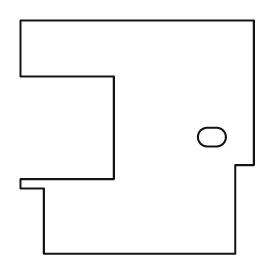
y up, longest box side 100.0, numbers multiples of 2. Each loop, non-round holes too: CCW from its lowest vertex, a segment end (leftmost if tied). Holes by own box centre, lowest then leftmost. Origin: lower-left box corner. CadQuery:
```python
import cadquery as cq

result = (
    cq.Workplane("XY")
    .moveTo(10.0, 0.0)
    .lineTo(92.0, 0.0)
    .lineTo(92.0, 38.0)
    .lineTo(100.0, 38.0)
    .lineTo(100.0, 100.0)
    .lineTo(0.0, 100.0)
    .lineTo(0.0, 76.0)
    .lineTo(40.0, 76.0)
    .lineTo(40.0, 32.0)
    .lineTo(0.0, 32.0)
    .lineTo(0.0, 28.0)
    .lineTo(10.0, 28.0)
    .close()
    .moveTo(80.0, 46.0)
    .lineTo(84.0, 46.0)
    .threePointArc((88.0, 50.0), (84.0, 54.0))
    .lineTo(80.0, 54.0)
    .threePointArc((76.0, 50.0), (80.0, 46.0))
    .close()
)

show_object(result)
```